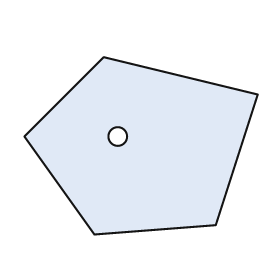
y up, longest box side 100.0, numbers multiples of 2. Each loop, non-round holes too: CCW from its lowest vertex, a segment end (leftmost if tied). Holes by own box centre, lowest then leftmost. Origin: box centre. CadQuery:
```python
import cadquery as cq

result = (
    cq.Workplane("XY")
    .moveTo(-20.0, -38.0)
    .lineTo(32.0, -34.0)
    .lineTo(50.0, 22.0)
    .lineTo(-16.0, 38.0)
    .lineTo(-50.0, 4.0)
    .close()
    .moveTo(-10.0, 4.0)
    .circle(4.0)
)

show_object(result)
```